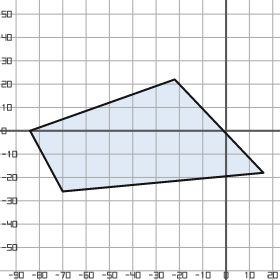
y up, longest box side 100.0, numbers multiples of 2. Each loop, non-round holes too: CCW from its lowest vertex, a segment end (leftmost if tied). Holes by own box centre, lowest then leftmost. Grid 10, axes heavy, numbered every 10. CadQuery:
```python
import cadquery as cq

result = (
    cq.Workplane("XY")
    .moveTo(-70.0, -26.0)
    .lineTo(16.0, -18.0)
    .lineTo(-22.0, 22.0)
    .lineTo(-84.0, 0.0)
    .close()
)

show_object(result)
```